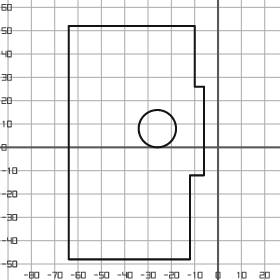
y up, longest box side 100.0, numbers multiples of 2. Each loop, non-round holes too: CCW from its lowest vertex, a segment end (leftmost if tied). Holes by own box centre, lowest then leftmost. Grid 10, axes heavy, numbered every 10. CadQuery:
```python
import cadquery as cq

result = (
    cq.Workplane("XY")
    .moveTo(-64.0, -48.0)
    .lineTo(-12.0, -48.0)
    .lineTo(-12.0, -12.0)
    .lineTo(-6.0, -12.0)
    .lineTo(-6.0, 26.0)
    .lineTo(-10.0, 26.0)
    .lineTo(-10.0, 52.0)
    .lineTo(-64.0, 52.0)
    .close()
    .moveTo(-26.0, 8.0)
    .circle(8.0)
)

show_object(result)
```